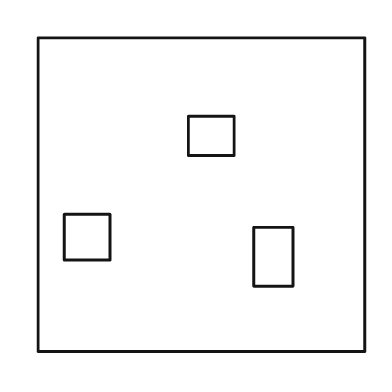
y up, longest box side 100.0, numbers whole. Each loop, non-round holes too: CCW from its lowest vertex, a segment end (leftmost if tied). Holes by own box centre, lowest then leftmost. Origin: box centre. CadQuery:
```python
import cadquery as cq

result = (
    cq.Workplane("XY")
    .moveTo(-50.0, -48.0)
    .lineTo(50.0, -48.0)
    .lineTo(50.0, 48.0)
    .lineTo(-50.0, 48.0)
    .close()
    .moveTo(16.0, -28.0)
    .lineTo(28.0, -28.0)
    .lineTo(28.0, -10.0)
    .lineTo(16.0, -10.0)
    .close()
    .moveTo(-42.0, -20.0)
    .lineTo(-28.0, -20.0)
    .lineTo(-28.0, -6.0)
    .lineTo(-42.0, -6.0)
    .close()
    .moveTo(-4.0, 12.0)
    .lineTo(10.0, 12.0)
    .lineTo(10.0, 24.0)
    .lineTo(-4.0, 24.0)
    .close()
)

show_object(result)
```